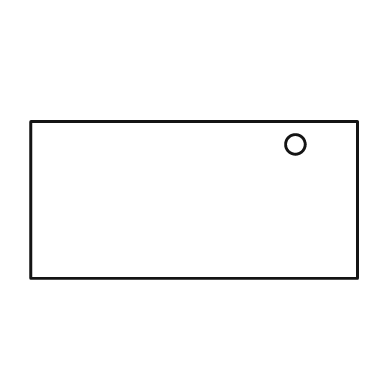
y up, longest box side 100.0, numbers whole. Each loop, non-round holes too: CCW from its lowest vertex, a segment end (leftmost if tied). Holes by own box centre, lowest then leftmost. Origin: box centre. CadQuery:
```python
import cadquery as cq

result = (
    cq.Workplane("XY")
    .moveTo(-50.0, -24.0)
    .lineTo(50.0, -24.0)
    .lineTo(50.0, 24.0)
    .lineTo(-50.0, 24.0)
    .close()
    .moveTo(31.0, 17.0)
    .circle(3.0)
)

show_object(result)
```